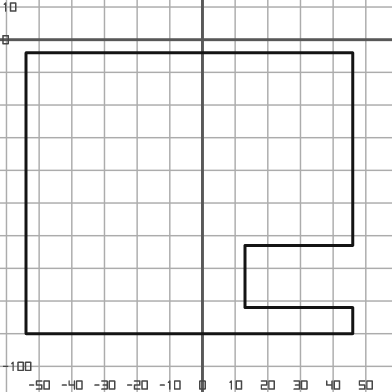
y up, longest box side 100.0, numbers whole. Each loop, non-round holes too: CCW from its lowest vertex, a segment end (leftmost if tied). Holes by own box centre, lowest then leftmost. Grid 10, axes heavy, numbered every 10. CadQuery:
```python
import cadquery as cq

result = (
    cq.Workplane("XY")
    .moveTo(-54.0, -90.0)
    .lineTo(46.0, -90.0)
    .lineTo(46.0, -82.0)
    .lineTo(13.0, -82.0)
    .lineTo(13.0, -63.0)
    .lineTo(46.0, -63.0)
    .lineTo(46.0, -4.0)
    .lineTo(-54.0, -4.0)
    .close()
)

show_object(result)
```